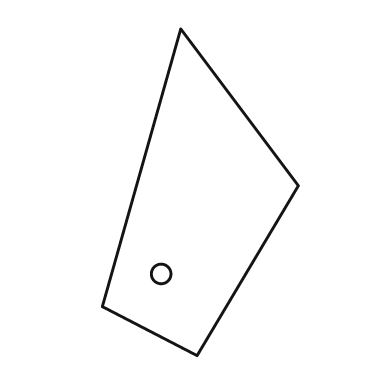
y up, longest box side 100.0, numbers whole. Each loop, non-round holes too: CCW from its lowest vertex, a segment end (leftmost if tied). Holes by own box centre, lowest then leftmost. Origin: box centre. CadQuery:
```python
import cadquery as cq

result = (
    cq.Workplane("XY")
    .moveTo(-1.0, -50.0)
    .lineTo(30.0, 2.0)
    .lineTo(-6.0, 50.0)
    .lineTo(-30.0, -35.0)
    .close()
    .moveTo(-12.0, -25.0)
    .circle(3.0)
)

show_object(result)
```